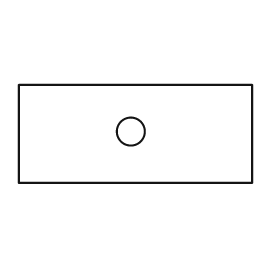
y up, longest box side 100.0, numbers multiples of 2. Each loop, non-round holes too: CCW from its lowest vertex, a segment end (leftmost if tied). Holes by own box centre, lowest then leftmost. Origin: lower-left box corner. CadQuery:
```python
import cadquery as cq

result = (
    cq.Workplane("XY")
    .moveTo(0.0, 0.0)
    .lineTo(100.0, 0.0)
    .lineTo(100.0, 42.0)
    .lineTo(0.0, 42.0)
    .close()
    .moveTo(48.0, 22.0)
    .circle(6.0)
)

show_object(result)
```